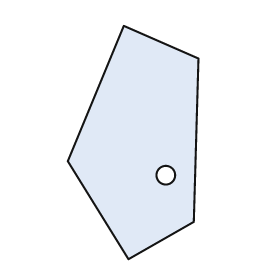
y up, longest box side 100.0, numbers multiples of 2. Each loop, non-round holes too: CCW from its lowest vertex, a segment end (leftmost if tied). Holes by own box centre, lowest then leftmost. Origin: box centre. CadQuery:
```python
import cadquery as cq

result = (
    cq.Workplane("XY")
    .moveTo(-2.0, -50.0)
    .lineTo(26.0, -34.0)
    .lineTo(28.0, 36.0)
    .lineTo(-4.0, 50.0)
    .lineTo(-28.0, -8.0)
    .close()
    .moveTo(14.0, -14.0)
    .circle(4.0)
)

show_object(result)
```